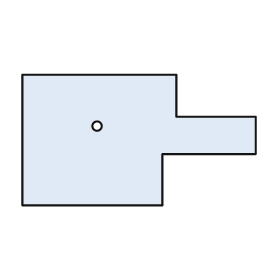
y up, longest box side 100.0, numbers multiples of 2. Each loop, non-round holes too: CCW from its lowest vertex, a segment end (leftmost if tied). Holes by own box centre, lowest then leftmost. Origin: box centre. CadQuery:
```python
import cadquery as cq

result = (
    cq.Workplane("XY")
    .moveTo(-50.0, -28.0)
    .lineTo(10.0, -28.0)
    .lineTo(10.0, -6.0)
    .lineTo(50.0, -6.0)
    .lineTo(50.0, 10.0)
    .lineTo(16.0, 10.0)
    .lineTo(16.0, 28.0)
    .lineTo(-50.0, 28.0)
    .close()
    .moveTo(-18.0, 6.0)
    .circle(2.0)
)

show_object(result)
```